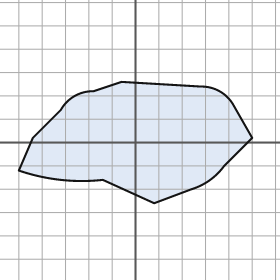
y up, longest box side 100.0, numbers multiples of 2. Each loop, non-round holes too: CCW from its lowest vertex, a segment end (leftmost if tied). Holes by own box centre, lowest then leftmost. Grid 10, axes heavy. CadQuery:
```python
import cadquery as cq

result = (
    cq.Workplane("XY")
    .moveTo(8.0, -26.0)
    .lineTo(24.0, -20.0)
    .threePointArc((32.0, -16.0), (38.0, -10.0))
    .lineTo(50.0, 2.0)
    .lineTo(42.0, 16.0)
    .threePointArc((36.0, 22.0), (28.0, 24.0))
    .lineTo(-6.0, 26.0)
    .lineTo(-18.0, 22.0)
    .threePointArc((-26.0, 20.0), (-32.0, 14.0))
    .lineTo(-44.0, 2.0)
    .lineTo(-50.0, -12.0)
    .threePointArc((-32.0, -16.0), (-14.0, -16.0))
    .close()
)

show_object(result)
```